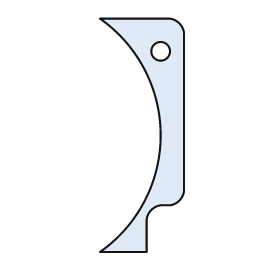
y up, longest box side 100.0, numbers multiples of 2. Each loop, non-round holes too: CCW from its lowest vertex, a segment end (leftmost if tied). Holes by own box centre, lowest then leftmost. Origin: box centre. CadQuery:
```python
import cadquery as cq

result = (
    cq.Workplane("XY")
    .moveTo(-18.0, -50.0)
    .lineTo(2.0, -50.0)
    .lineTo(2.0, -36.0)
    .threePointArc((4.0, -32.0), (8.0, -30.0))
    .lineTo(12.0, -30.0)
    .threePointArc((16.0, -28.0), (18.0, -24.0))
    .lineTo(18.0, 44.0)
    .threePointArc((16.0, 48.0), (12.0, 50.0))
    .lineTo(-18.0, 50.0)
    .threePointArc((8.0, 0.0), (-18.0, -50.0))
    .close()
    .moveTo(8.0, 36.0)
    .circle(4.0)
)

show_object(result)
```